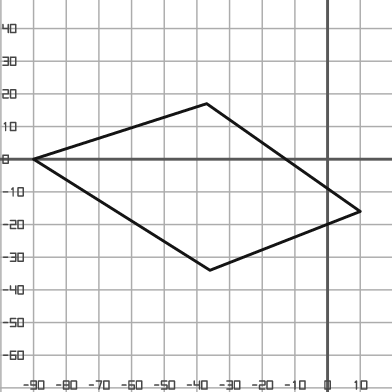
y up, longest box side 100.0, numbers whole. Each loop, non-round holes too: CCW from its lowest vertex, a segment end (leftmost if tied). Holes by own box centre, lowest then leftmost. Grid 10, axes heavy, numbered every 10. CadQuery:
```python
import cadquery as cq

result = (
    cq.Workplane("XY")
    .moveTo(-36.0, -34.0)
    .lineTo(10.0, -16.0)
    .lineTo(-37.0, 17.0)
    .lineTo(-90.0, 0.0)
    .close()
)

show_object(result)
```